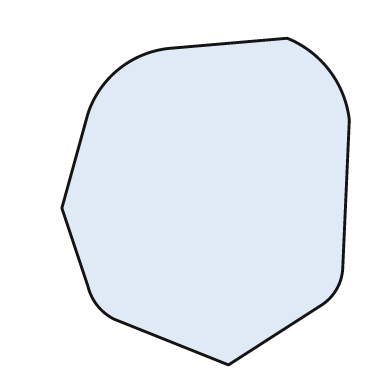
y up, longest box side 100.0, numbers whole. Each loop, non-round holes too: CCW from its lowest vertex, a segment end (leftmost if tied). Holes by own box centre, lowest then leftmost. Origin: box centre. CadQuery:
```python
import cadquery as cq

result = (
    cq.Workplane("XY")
    .moveTo(7.0, -50.0)
    .lineTo(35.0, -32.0)
    .threePointArc((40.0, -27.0), (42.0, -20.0))
    .lineTo(44.0, 25.0)
    .threePointArc((38.0, 40.0), (25.0, 50.0))
    .lineTo(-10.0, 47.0)
    .threePointArc((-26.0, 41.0), (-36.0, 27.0))
    .lineTo(-44.0, -2.0)
    .lineTo(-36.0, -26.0)
    .threePointArc((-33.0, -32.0), (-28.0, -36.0))
    .close()
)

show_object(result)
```